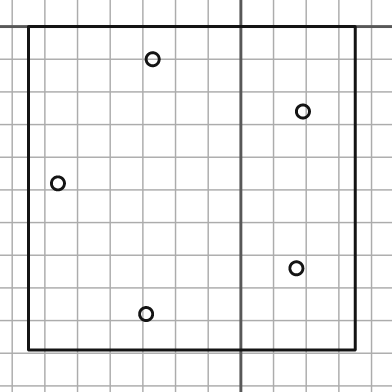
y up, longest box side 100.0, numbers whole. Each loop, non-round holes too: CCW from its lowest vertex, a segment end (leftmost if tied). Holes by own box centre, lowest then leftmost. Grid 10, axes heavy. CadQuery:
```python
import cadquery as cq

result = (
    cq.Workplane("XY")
    .moveTo(-65.0, -99.0)
    .lineTo(35.0, -99.0)
    .lineTo(35.0, 0.0)
    .lineTo(-65.0, 0.0)
    .close()
    .moveTo(-29.0, -88.0)
    .circle(2.0)
    .moveTo(17.0, -74.0)
    .circle(2.0)
    .moveTo(-56.0, -48.0)
    .circle(2.0)
    .moveTo(19.0, -26.0)
    .circle(2.0)
    .moveTo(-27.0, -10.0)
    .circle(2.0)
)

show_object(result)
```